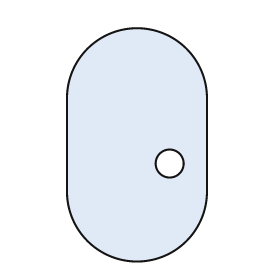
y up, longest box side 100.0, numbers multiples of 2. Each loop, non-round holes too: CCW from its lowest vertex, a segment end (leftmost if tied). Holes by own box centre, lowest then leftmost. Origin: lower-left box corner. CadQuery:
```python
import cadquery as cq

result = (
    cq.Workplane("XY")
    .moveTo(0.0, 30.0)
    .threePointArc((30.0, 0.0), (60.0, 30.0))
    .lineTo(60.0, 70.0)
    .threePointArc((30.0, 100.0), (0.0, 70.0))
    .close()
    .moveTo(44.0, 42.0)
    .circle(6.0)
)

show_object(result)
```